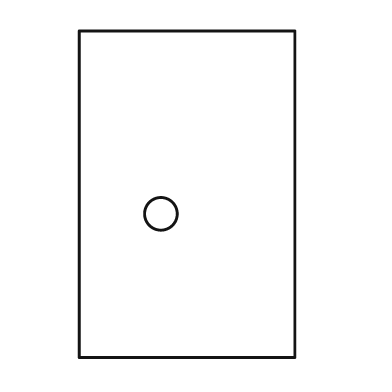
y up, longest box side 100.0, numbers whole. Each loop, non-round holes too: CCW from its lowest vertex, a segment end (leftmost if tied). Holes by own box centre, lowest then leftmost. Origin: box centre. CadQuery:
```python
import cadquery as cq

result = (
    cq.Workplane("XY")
    .moveTo(-33.0, -50.0)
    .lineTo(33.0, -50.0)
    .lineTo(33.0, 50.0)
    .lineTo(-33.0, 50.0)
    .close()
    .moveTo(-8.0, -6.0)
    .circle(5.0)
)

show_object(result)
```